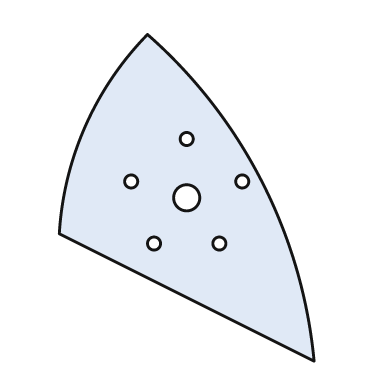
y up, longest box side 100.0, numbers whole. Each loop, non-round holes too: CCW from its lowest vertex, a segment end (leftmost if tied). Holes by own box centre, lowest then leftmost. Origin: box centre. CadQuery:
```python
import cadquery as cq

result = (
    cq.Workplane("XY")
    .moveTo(39.0, -50.0)
    .threePointArc((23.0, 5.0), (-12.0, 50.0))
    .threePointArc((-31.0, 22.0), (-39.0, -11.0))
    .close()
    .moveTo(-10.0, -14.0)
    .circle(2.0)
    .moveTo(10.0, -14.0)
    .circle(2.0)
    .moveTo(0.0, 0.0)
    .circle(4.0)
    .moveTo(-17.0, 5.0)
    .circle(2.0)
    .moveTo(17.0, 5.0)
    .circle(2.0)
    .moveTo(0.0, 18.0)
    .circle(2.0)
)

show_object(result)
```